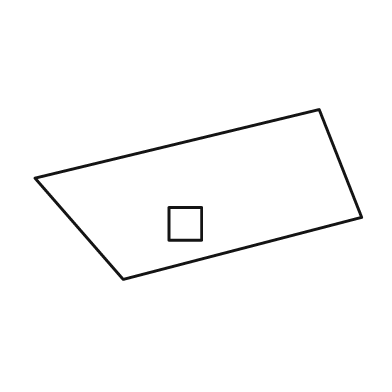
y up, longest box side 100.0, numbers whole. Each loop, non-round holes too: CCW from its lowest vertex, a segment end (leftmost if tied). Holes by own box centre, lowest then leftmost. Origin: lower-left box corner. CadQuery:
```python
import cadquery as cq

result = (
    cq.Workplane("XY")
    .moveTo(27.0, 0.0)
    .lineTo(100.0, 19.0)
    .lineTo(87.0, 52.0)
    .lineTo(0.0, 31.0)
    .close()
    .moveTo(41.0, 12.0)
    .lineTo(51.0, 12.0)
    .lineTo(51.0, 22.0)
    .lineTo(41.0, 22.0)
    .close()
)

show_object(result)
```